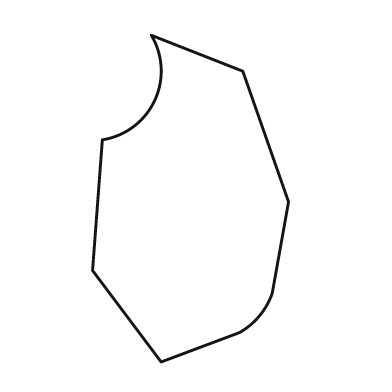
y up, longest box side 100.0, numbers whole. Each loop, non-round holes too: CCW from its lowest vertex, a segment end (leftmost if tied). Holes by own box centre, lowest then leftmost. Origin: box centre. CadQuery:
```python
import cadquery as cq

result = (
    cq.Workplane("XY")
    .moveTo(-9.0, -50.0)
    .lineTo(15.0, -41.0)
    .threePointArc((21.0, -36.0), (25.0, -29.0))
    .lineTo(30.0, -1.0)
    .lineTo(16.0, 39.0)
    .lineTo(-12.0, 50.0)
    .threePointArc((-11.0, 30.0), (-27.0, 18.0))
    .lineTo(-30.0, -22.0)
    .close()
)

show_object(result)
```